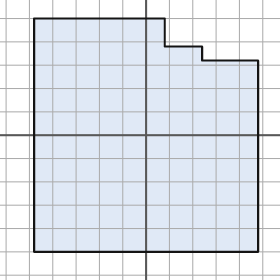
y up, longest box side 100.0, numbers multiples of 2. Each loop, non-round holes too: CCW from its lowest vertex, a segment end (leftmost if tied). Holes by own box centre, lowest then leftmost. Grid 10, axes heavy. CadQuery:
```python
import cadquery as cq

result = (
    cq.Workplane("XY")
    .moveTo(-48.0, -50.0)
    .lineTo(48.0, -50.0)
    .lineTo(48.0, 32.0)
    .lineTo(24.0, 32.0)
    .lineTo(24.0, 38.0)
    .lineTo(8.0, 38.0)
    .lineTo(8.0, 50.0)
    .lineTo(-48.0, 50.0)
    .close()
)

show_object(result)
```